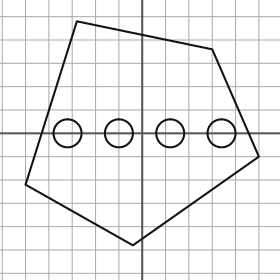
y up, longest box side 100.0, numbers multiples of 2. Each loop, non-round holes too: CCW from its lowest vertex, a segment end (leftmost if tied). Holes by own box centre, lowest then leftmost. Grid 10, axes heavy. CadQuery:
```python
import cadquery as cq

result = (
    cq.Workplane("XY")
    .moveTo(-4.0, -48.0)
    .lineTo(50.0, -10.0)
    .lineTo(30.0, 36.0)
    .lineTo(-28.0, 48.0)
    .lineTo(-50.0, -22.0)
    .close()
    .moveTo(-32.0, 0.0)
    .circle(6.0)
    .moveTo(-10.0, 0.0)
    .circle(6.0)
    .moveTo(12.0, 0.0)
    .circle(6.0)
    .moveTo(34.0, 0.0)
    .circle(6.0)
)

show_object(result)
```